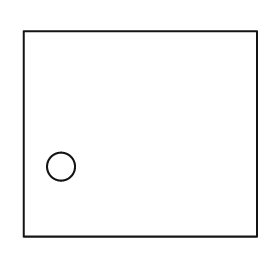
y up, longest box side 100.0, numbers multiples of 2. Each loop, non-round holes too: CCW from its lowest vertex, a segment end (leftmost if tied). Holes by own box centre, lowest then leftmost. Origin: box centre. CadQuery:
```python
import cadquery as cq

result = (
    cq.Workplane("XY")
    .moveTo(-50.0, -44.0)
    .lineTo(50.0, -44.0)
    .lineTo(50.0, 44.0)
    .lineTo(-50.0, 44.0)
    .close()
    .moveTo(-34.0, -14.0)
    .circle(6.0)
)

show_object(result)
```